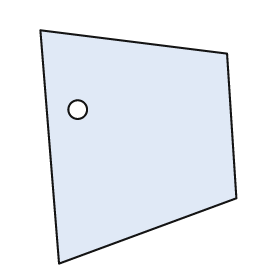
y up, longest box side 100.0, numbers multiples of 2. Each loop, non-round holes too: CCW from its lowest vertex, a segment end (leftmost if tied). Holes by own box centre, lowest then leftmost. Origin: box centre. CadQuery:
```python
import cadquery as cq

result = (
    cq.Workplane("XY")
    .moveTo(-34.0, -50.0)
    .lineTo(42.0, -22.0)
    .lineTo(38.0, 40.0)
    .lineTo(-42.0, 50.0)
    .close()
    .moveTo(-26.0, 16.0)
    .circle(4.0)
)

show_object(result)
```